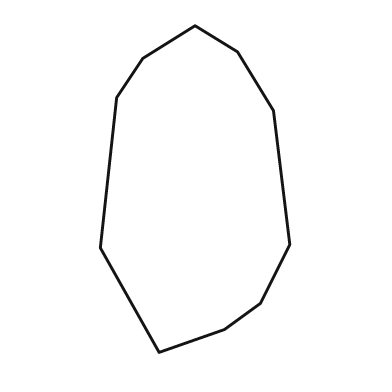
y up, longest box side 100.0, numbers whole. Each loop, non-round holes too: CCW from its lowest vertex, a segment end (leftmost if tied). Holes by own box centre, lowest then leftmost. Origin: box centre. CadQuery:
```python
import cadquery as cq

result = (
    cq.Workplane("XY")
    .moveTo(-11.0, -50.0)
    .lineTo(9.0, -43.0)
    .lineTo(20.0, -35.0)
    .lineTo(29.0, -17.0)
    .lineTo(24.0, 24.0)
    .lineTo(13.0, 42.0)
    .lineTo(0.0, 50.0)
    .lineTo(-16.0, 40.0)
    .lineTo(-24.0, 28.0)
    .lineTo(-29.0, -18.0)
    .close()
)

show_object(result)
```